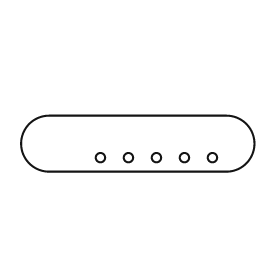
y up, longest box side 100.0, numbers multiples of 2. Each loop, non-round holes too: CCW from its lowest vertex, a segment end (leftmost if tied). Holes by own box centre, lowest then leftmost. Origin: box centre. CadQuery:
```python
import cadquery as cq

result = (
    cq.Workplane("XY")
    .moveTo(-38.0, -12.0)
    .lineTo(38.0, -12.0)
    .threePointArc((50.0, 0.0), (38.0, 12.0))
    .lineTo(-38.0, 12.0)
    .threePointArc((-50.0, 0.0), (-38.0, -12.0))
    .close()
    .moveTo(-16.0, -6.0)
    .circle(2.0)
    .moveTo(-4.0, -6.0)
    .circle(2.0)
    .moveTo(8.0, -6.0)
    .circle(2.0)
    .moveTo(20.0, -6.0)
    .circle(2.0)
    .moveTo(32.0, -6.0)
    .circle(2.0)
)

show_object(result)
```